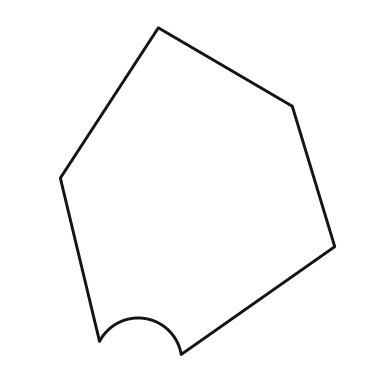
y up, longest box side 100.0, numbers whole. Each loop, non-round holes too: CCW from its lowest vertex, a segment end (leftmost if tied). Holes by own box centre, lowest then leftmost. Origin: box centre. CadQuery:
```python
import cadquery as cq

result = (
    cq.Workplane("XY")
    .moveTo(-5.0, -50.0)
    .lineTo(42.0, -17.0)
    .lineTo(29.0, 26.0)
    .lineTo(-12.0, 50.0)
    .lineTo(-42.0, 4.0)
    .lineTo(-30.0, -46.0)
    .threePointArc((-16.0, -39.0), (-5.0, -50.0))
    .close()
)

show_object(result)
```